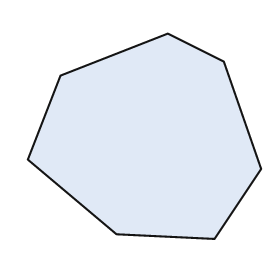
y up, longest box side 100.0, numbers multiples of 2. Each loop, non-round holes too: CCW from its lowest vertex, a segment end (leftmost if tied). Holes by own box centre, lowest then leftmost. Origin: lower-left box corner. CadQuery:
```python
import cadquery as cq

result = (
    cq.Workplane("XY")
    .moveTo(80.0, 0.0)
    .lineTo(100.0, 30.0)
    .lineTo(84.0, 76.0)
    .lineTo(60.0, 88.0)
    .lineTo(14.0, 70.0)
    .lineTo(0.0, 34.0)
    .lineTo(38.0, 2.0)
    .close()
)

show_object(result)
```